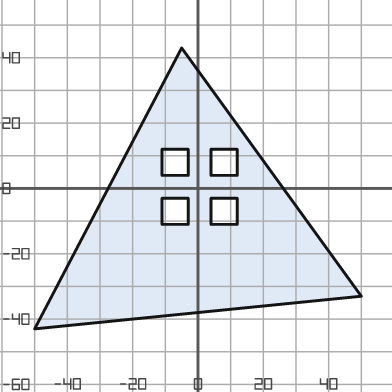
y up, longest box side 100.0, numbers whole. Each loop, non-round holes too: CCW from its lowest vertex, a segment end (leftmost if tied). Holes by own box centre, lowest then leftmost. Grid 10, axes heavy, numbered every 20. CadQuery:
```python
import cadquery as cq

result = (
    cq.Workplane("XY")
    .moveTo(-50.0, -43.0)
    .lineTo(50.0, -33.0)
    .lineTo(-5.0, 43.0)
    .close()
    .moveTo(-11.0, -11.0)
    .lineTo(-3.0, -11.0)
    .lineTo(-3.0, -3.0)
    .lineTo(-11.0, -3.0)
    .close()
    .moveTo(4.0, -11.0)
    .lineTo(12.0, -11.0)
    .lineTo(12.0, -3.0)
    .lineTo(4.0, -3.0)
    .close()
    .moveTo(-11.0, 4.0)
    .lineTo(-3.0, 4.0)
    .lineTo(-3.0, 12.0)
    .lineTo(-11.0, 12.0)
    .close()
    .moveTo(4.0, 4.0)
    .lineTo(12.0, 4.0)
    .lineTo(12.0, 12.0)
    .lineTo(4.0, 12.0)
    .close()
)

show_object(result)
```